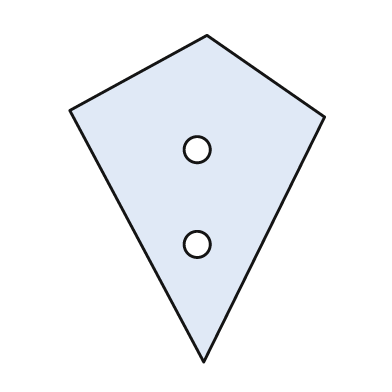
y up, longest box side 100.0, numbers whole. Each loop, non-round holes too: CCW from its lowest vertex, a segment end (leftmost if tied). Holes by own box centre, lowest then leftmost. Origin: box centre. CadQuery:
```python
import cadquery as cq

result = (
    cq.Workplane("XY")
    .moveTo(2.0, -50.0)
    .lineTo(39.0, 25.0)
    .lineTo(3.0, 50.0)
    .lineTo(-39.0, 27.0)
    .close()
    .moveTo(0.0, -14.0)
    .circle(4.0)
    .moveTo(0.0, 15.0)
    .circle(4.0)
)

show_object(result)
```